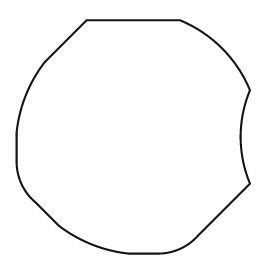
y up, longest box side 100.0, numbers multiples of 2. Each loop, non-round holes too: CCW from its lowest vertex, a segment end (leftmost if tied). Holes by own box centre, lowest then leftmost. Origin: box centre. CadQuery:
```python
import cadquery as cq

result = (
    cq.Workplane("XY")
    .moveTo(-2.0, -50.0)
    .lineTo(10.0, -50.0)
    .threePointArc((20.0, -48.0), (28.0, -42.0))
    .lineTo(50.0, -20.0)
    .threePointArc((46.0, 0.0), (50.0, 20.0))
    .threePointArc((38.0, 38.0), (20.0, 50.0))
    .lineTo(-20.0, 50.0)
    .lineTo(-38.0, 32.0)
    .threePointArc((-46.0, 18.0), (-50.0, 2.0))
    .lineTo(-50.0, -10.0)
    .threePointArc((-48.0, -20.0), (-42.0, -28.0))
    .lineTo(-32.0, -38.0)
    .threePointArc((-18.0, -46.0), (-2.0, -50.0))
    .close()
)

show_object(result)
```